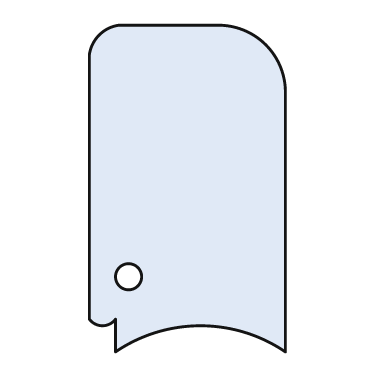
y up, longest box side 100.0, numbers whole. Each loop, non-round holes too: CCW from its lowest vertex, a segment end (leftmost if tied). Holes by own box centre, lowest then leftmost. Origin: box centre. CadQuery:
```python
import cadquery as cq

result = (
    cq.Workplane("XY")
    .moveTo(-22.0, -50.0)
    .threePointArc((4.0, -42.0), (30.0, -50.0))
    .lineTo(30.0, 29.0)
    .threePointArc((24.0, 44.0), (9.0, 50.0))
    .lineTo(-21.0, 50.0)
    .threePointArc((-27.0, 47.0), (-30.0, 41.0))
    .lineTo(-30.0, -40.0)
    .threePointArc((-26.0, -42.0), (-22.0, -40.0))
    .close()
    .moveTo(-18.0, -27.0)
    .circle(4.0)
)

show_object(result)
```